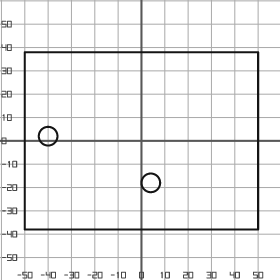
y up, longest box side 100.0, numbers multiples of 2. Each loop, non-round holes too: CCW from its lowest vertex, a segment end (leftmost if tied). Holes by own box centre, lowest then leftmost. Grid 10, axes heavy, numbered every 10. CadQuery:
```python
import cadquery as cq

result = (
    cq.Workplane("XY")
    .moveTo(-50.0, -38.0)
    .lineTo(50.0, -38.0)
    .lineTo(50.0, 38.0)
    .lineTo(-50.0, 38.0)
    .close()
    .moveTo(4.0, -18.0)
    .circle(4.0)
    .moveTo(-40.0, 2.0)
    .circle(4.0)
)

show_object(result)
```